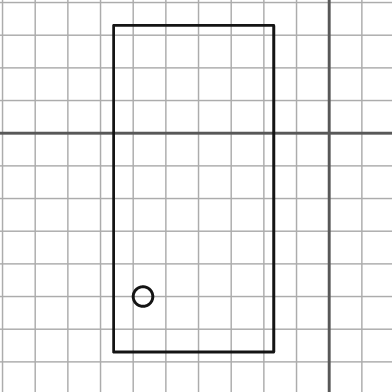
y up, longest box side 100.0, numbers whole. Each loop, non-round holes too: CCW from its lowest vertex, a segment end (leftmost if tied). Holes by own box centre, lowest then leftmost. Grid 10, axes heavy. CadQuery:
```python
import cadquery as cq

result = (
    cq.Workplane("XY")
    .moveTo(-66.0, -67.0)
    .lineTo(-17.0, -67.0)
    .lineTo(-17.0, 33.0)
    .lineTo(-66.0, 33.0)
    .close()
    .moveTo(-57.0, -50.0)
    .circle(3.0)
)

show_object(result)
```